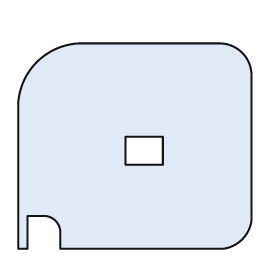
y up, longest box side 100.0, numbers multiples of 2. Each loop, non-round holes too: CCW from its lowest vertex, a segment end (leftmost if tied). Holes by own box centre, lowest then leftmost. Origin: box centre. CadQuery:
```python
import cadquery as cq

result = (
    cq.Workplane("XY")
    .moveTo(-50.0, -44.0)
    .lineTo(-46.0, -44.0)
    .lineTo(-46.0, -30.0)
    .lineTo(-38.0, -30.0)
    .threePointArc((-34.0, -32.0), (-32.0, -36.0))
    .lineTo(-32.0, -44.0)
    .lineTo(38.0, -44.0)
    .threePointArc((46.0, -40.0), (50.0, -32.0))
    .lineTo(50.0, 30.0)
    .threePointArc((46.0, 40.0), (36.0, 44.0))
    .lineTo(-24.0, 44.0)
    .threePointArc((-42.0, 36.0), (-50.0, 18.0))
    .close()
    .moveTo(-4.0, -8.0)
    .lineTo(12.0, -8.0)
    .lineTo(12.0, 4.0)
    .lineTo(-4.0, 4.0)
    .close()
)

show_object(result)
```